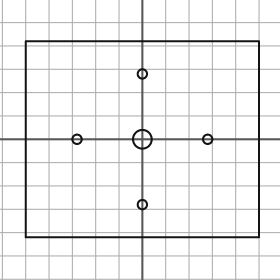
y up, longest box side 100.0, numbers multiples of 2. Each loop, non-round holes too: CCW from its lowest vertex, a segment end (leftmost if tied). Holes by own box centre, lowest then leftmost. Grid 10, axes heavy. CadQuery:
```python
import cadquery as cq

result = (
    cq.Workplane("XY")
    .moveTo(-50.0, -42.0)
    .lineTo(50.0, -42.0)
    .lineTo(50.0, 42.0)
    .lineTo(-50.0, 42.0)
    .close()
    .moveTo(0.0, -28.0)
    .circle(2.0)
    .moveTo(-28.0, 0.0)
    .circle(2.0)
    .moveTo(0.0, 0.0)
    .circle(4.0)
    .moveTo(28.0, 0.0)
    .circle(2.0)
    .moveTo(0.0, 28.0)
    .circle(2.0)
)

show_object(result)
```